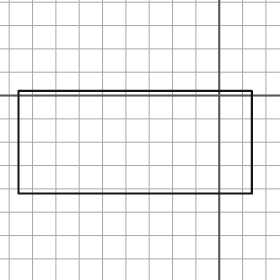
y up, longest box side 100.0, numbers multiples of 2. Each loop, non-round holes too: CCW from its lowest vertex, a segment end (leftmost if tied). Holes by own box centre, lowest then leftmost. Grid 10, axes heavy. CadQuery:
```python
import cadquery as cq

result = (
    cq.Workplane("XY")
    .moveTo(-86.0, -42.0)
    .lineTo(14.0, -42.0)
    .lineTo(14.0, 2.0)
    .lineTo(-86.0, 2.0)
    .close()
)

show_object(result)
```